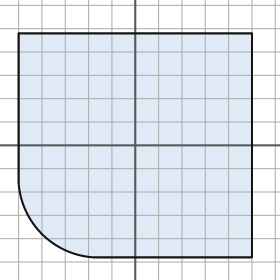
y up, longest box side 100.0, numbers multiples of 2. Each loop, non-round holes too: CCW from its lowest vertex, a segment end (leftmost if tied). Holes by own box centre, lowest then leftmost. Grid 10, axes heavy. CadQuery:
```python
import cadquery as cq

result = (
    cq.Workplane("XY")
    .moveTo(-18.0, -48.0)
    .lineTo(50.0, -48.0)
    .lineTo(50.0, 48.0)
    .lineTo(-50.0, 48.0)
    .lineTo(-50.0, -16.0)
    .threePointArc((-40.0, -38.0), (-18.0, -48.0))
    .close()
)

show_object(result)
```